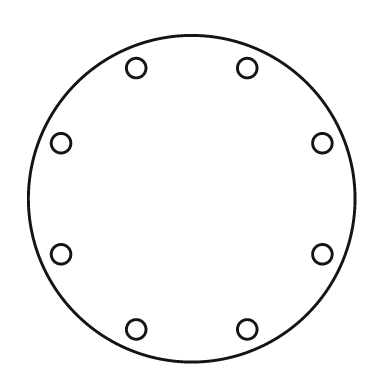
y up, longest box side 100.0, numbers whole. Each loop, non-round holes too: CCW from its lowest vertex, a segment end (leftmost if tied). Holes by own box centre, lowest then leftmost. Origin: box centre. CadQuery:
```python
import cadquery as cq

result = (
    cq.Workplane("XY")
    .moveTo(0.0, 0.0)
    .circle(50.0)
    .moveTo(-17.0, -40.0)
    .circle(3.0)
    .moveTo(17.0, -40.0)
    .circle(3.0)
    .moveTo(-40.0, -17.0)
    .circle(3.0)
    .moveTo(40.0, -17.0)
    .circle(3.0)
    .moveTo(-40.0, 17.0)
    .circle(3.0)
    .moveTo(40.0, 17.0)
    .circle(3.0)
    .moveTo(-17.0, 40.0)
    .circle(3.0)
    .moveTo(17.0, 40.0)
    .circle(3.0)
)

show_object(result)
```